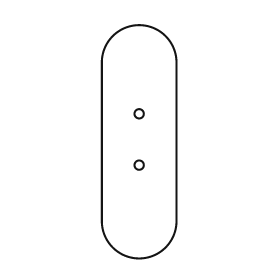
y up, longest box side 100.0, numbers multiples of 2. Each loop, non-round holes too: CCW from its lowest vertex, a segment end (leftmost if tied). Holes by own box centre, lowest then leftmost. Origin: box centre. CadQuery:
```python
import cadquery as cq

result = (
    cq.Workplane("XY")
    .moveTo(-16.0, -34.0)
    .threePointArc((0.0, -50.0), (16.0, -34.0))
    .lineTo(16.0, 34.0)
    .threePointArc((0.0, 50.0), (-16.0, 34.0))
    .close()
    .moveTo(0.0, -10.0)
    .circle(2.0)
    .moveTo(0.0, 12.0)
    .circle(2.0)
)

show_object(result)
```